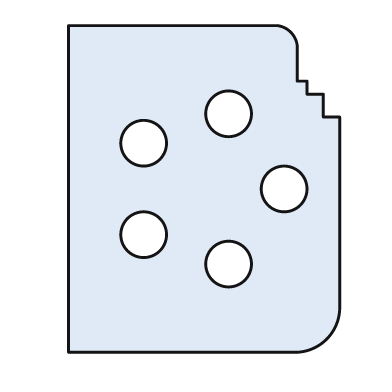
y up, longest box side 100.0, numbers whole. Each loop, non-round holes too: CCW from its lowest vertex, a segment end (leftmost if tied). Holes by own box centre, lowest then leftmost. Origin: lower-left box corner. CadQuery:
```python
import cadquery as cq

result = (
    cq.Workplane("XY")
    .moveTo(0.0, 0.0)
    .lineTo(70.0, 0.0)
    .threePointArc((79.0, 4.0), (83.0, 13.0))
    .lineTo(83.0, 72.0)
    .lineTo(78.0, 72.0)
    .lineTo(78.0, 79.0)
    .lineTo(73.0, 79.0)
    .lineTo(73.0, 83.0)
    .lineTo(70.0, 83.0)
    .lineTo(70.0, 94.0)
    .threePointArc((68.0, 98.0), (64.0, 100.0))
    .lineTo(0.0, 100.0)
    .close()
    .moveTo(49.0, 27.0)
    .circle(7.0)
    .moveTo(23.0, 36.0)
    .circle(7.0)
    .moveTo(66.0, 50.0)
    .circle(7.0)
    .moveTo(23.0, 64.0)
    .circle(7.0)
    .moveTo(49.0, 73.0)
    .circle(7.0)
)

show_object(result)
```